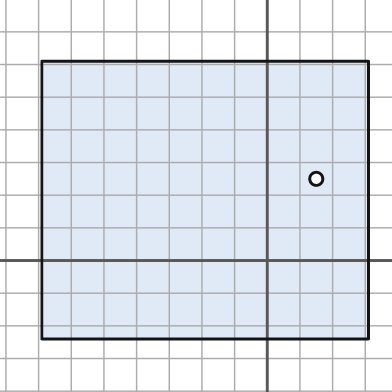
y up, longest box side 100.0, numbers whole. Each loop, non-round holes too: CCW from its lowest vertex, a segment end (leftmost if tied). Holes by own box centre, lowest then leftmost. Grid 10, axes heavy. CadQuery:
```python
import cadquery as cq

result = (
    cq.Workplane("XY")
    .moveTo(-69.0, -24.0)
    .lineTo(31.0, -24.0)
    .lineTo(31.0, 61.0)
    .lineTo(-69.0, 61.0)
    .close()
    .moveTo(15.0, 25.0)
    .circle(2.0)
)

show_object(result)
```